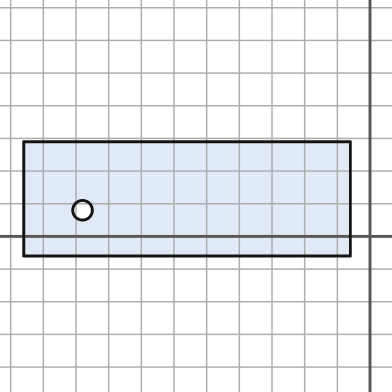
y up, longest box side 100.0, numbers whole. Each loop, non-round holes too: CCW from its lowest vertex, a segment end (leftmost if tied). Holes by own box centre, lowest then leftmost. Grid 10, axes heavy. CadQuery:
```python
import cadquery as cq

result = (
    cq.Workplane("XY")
    .moveTo(-106.0, -6.0)
    .lineTo(-6.0, -6.0)
    .lineTo(-6.0, 29.0)
    .lineTo(-106.0, 29.0)
    .close()
    .moveTo(-88.0, 8.0)
    .circle(3.0)
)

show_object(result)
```